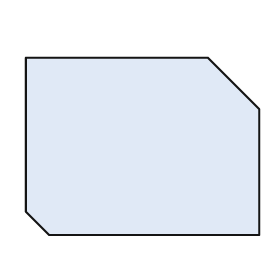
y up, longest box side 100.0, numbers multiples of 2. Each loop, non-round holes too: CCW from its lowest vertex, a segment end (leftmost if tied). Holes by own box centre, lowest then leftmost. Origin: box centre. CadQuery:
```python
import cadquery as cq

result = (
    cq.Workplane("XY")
    .moveTo(-40.0, -38.0)
    .lineTo(50.0, -38.0)
    .lineTo(50.0, 16.0)
    .lineTo(28.0, 38.0)
    .lineTo(-50.0, 38.0)
    .lineTo(-50.0, -28.0)
    .close()
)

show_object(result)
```